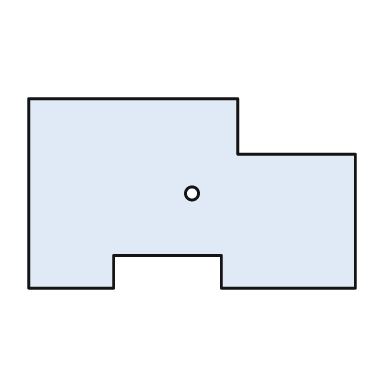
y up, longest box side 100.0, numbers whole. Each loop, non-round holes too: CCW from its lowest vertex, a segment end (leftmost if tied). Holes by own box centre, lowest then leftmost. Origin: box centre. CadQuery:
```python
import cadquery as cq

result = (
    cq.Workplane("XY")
    .moveTo(-50.0, -29.0)
    .lineTo(-24.0, -29.0)
    .lineTo(-24.0, -19.0)
    .lineTo(9.0, -19.0)
    .lineTo(9.0, -29.0)
    .lineTo(50.0, -29.0)
    .lineTo(50.0, 12.0)
    .lineTo(14.0, 12.0)
    .lineTo(14.0, 29.0)
    .lineTo(-50.0, 29.0)
    .close()
    .moveTo(0.0, 0.0)
    .circle(2.0)
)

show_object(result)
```